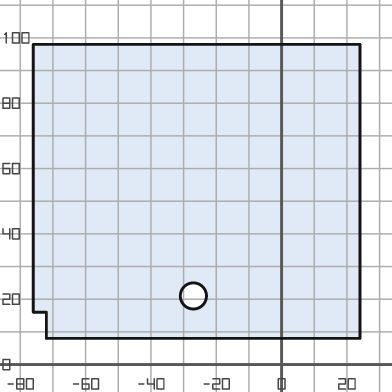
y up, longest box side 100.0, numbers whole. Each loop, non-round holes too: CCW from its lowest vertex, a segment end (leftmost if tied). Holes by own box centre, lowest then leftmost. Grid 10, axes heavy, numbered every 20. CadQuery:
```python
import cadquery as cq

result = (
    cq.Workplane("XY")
    .moveTo(-72.0, 8.0)
    .lineTo(24.0, 8.0)
    .lineTo(24.0, 98.0)
    .lineTo(-76.0, 98.0)
    .lineTo(-76.0, 16.0)
    .lineTo(-72.0, 16.0)
    .close()
    .moveTo(-27.0, 21.0)
    .circle(4.0)
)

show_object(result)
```